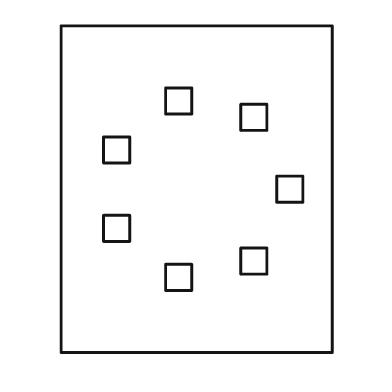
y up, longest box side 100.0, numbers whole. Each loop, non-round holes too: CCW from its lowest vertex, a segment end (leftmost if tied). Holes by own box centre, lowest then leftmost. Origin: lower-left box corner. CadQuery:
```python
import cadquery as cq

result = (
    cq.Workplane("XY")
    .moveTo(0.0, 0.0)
    .lineTo(83.0, 0.0)
    .lineTo(83.0, 100.0)
    .lineTo(0.0, 100.0)
    .close()
    .moveTo(32.0, 19.0)
    .lineTo(40.0, 19.0)
    .lineTo(40.0, 27.0)
    .lineTo(32.0, 27.0)
    .close()
    .moveTo(55.0, 24.0)
    .lineTo(63.0, 24.0)
    .lineTo(63.0, 32.0)
    .lineTo(55.0, 32.0)
    .close()
    .moveTo(13.0, 34.0)
    .lineTo(21.0, 34.0)
    .lineTo(21.0, 42.0)
    .lineTo(13.0, 42.0)
    .close()
    .moveTo(66.0, 46.0)
    .lineTo(74.0, 46.0)
    .lineTo(74.0, 54.0)
    .lineTo(66.0, 54.0)
    .close()
    .moveTo(13.0, 58.0)
    .lineTo(21.0, 58.0)
    .lineTo(21.0, 66.0)
    .lineTo(13.0, 66.0)
    .close()
    .moveTo(55.0, 68.0)
    .lineTo(63.0, 68.0)
    .lineTo(63.0, 76.0)
    .lineTo(55.0, 76.0)
    .close()
    .moveTo(32.0, 73.0)
    .lineTo(40.0, 73.0)
    .lineTo(40.0, 81.0)
    .lineTo(32.0, 81.0)
    .close()
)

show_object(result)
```